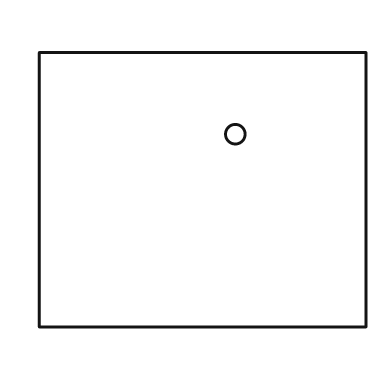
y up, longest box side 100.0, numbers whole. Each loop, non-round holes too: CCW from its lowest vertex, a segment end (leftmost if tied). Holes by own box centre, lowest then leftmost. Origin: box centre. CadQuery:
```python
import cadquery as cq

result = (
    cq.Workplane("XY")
    .moveTo(-50.0, -42.0)
    .lineTo(50.0, -42.0)
    .lineTo(50.0, 42.0)
    .lineTo(-50.0, 42.0)
    .close()
    .moveTo(10.0, 17.0)
    .circle(3.0)
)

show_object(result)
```